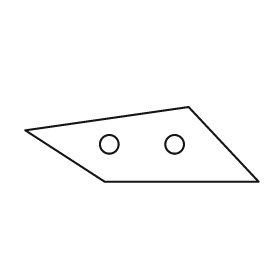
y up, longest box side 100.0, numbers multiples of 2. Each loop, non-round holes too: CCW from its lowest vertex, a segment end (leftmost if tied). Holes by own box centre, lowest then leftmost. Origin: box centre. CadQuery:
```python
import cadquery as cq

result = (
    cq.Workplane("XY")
    .moveTo(-16.0, -16.0)
    .lineTo(50.0, -16.0)
    .lineTo(20.0, 16.0)
    .lineTo(-50.0, 6.0)
    .close()
    .moveTo(-14.0, 0.0)
    .circle(4.0)
    .moveTo(14.0, 0.0)
    .circle(4.0)
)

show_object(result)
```